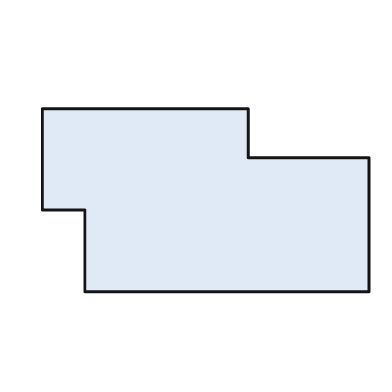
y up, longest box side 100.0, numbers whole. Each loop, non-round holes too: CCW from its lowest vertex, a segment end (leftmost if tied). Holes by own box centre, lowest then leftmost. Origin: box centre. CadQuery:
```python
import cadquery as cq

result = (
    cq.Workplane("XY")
    .moveTo(-37.0, -28.0)
    .lineTo(50.0, -28.0)
    .lineTo(50.0, 13.0)
    .lineTo(13.0, 13.0)
    .lineTo(13.0, 28.0)
    .lineTo(-50.0, 28.0)
    .lineTo(-50.0, -3.0)
    .lineTo(-37.0, -3.0)
    .close()
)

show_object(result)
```